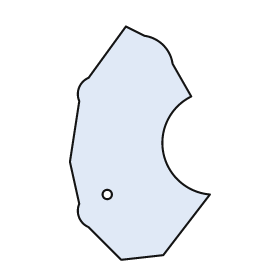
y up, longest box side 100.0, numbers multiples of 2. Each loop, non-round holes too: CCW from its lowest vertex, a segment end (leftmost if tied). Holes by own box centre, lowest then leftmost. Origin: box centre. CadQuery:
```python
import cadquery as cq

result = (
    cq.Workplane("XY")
    .moveTo(-8.0, -50.0)
    .lineTo(10.0, -48.0)
    .lineTo(30.0, -22.0)
    .threePointArc((10.0, -4.0), (22.0, 20.0))
    .lineTo(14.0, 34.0)
    .threePointArc((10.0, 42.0), (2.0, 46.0))
    .lineTo(-6.0, 50.0)
    .lineTo(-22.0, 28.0)
    .threePointArc((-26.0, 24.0), (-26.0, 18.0))
    .lineTo(-30.0, -8.0)
    .lineTo(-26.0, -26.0)
    .threePointArc((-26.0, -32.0), (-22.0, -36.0))
    .close()
    .moveTo(-14.0, -22.0)
    .circle(2.0)
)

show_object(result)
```